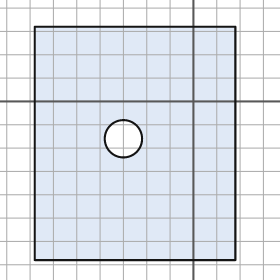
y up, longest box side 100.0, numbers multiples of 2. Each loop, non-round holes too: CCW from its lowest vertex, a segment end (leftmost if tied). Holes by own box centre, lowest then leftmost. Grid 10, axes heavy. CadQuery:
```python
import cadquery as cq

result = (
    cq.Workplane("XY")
    .moveTo(-68.0, -68.0)
    .lineTo(18.0, -68.0)
    .lineTo(18.0, 32.0)
    .lineTo(-68.0, 32.0)
    .close()
    .moveTo(-30.0, -16.0)
    .circle(8.0)
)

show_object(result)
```